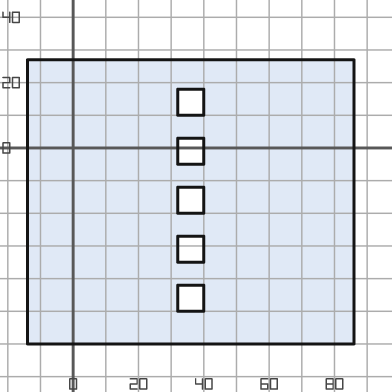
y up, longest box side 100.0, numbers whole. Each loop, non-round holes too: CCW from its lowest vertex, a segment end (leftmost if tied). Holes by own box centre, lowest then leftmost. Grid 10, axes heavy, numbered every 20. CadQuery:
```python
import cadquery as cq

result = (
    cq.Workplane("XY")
    .moveTo(-14.0, -60.0)
    .lineTo(86.0, -60.0)
    .lineTo(86.0, 27.0)
    .lineTo(-14.0, 27.0)
    .close()
    .moveTo(32.0, -50.0)
    .lineTo(40.0, -50.0)
    .lineTo(40.0, -42.0)
    .lineTo(32.0, -42.0)
    .close()
    .moveTo(32.0, -35.0)
    .lineTo(40.0, -35.0)
    .lineTo(40.0, -27.0)
    .lineTo(32.0, -27.0)
    .close()
    .moveTo(32.0, -20.0)
    .lineTo(40.0, -20.0)
    .lineTo(40.0, -12.0)
    .lineTo(32.0, -12.0)
    .close()
    .moveTo(32.0, -5.0)
    .lineTo(40.0, -5.0)
    .lineTo(40.0, 3.0)
    .lineTo(32.0, 3.0)
    .close()
    .moveTo(32.0, 10.0)
    .lineTo(40.0, 10.0)
    .lineTo(40.0, 18.0)
    .lineTo(32.0, 18.0)
    .close()
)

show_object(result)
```